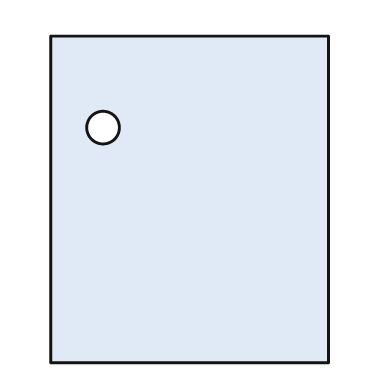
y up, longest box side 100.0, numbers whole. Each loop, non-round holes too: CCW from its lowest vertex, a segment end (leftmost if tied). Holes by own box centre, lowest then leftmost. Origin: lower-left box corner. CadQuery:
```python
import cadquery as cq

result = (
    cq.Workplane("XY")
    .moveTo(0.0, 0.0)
    .lineTo(85.0, 0.0)
    .lineTo(85.0, 100.0)
    .lineTo(0.0, 100.0)
    .close()
    .moveTo(16.0, 72.0)
    .circle(5.0)
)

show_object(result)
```